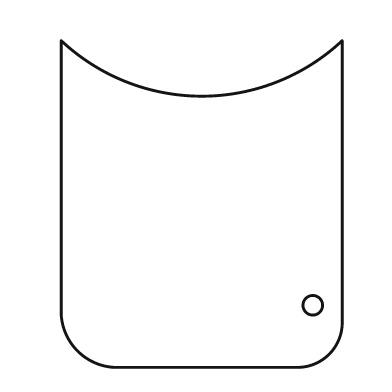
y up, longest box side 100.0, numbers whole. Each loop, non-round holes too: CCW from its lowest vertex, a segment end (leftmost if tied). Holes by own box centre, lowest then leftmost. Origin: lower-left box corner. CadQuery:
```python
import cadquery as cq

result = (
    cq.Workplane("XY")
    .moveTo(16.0, 0.0)
    .lineTo(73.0, 0.0)
    .threePointArc((82.0, 4.0), (86.0, 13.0))
    .lineTo(86.0, 100.0)
    .threePointArc((43.0, 83.0), (0.0, 100.0))
    .lineTo(0.0, 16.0)
    .threePointArc((5.0, 5.0), (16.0, 0.0))
    .close()
    .moveTo(77.0, 19.0)
    .circle(3.0)
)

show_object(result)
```